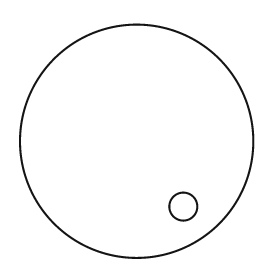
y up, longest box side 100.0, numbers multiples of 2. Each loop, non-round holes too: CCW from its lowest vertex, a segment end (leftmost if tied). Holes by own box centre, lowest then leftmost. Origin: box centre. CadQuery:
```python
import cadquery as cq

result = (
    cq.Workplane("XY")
    .moveTo(0.0, 0.0)
    .circle(50.0)
    .moveTo(20.0, -28.0)
    .circle(6.0)
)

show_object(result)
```